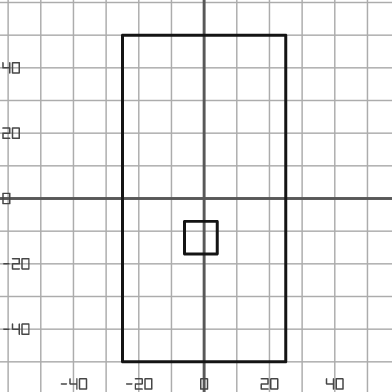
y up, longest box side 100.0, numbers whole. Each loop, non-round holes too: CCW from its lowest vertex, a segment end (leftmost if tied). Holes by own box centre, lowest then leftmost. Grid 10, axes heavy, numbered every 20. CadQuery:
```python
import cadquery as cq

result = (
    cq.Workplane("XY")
    .moveTo(-25.0, -50.0)
    .lineTo(25.0, -50.0)
    .lineTo(25.0, 50.0)
    .lineTo(-25.0, 50.0)
    .close()
    .moveTo(-6.0, -17.0)
    .lineTo(4.0, -17.0)
    .lineTo(4.0, -7.0)
    .lineTo(-6.0, -7.0)
    .close()
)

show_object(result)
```